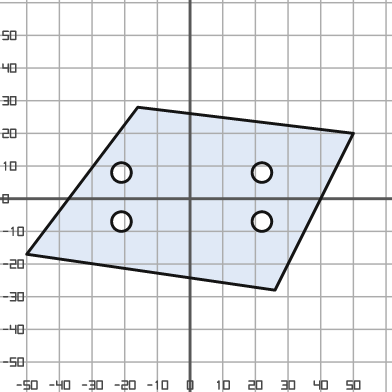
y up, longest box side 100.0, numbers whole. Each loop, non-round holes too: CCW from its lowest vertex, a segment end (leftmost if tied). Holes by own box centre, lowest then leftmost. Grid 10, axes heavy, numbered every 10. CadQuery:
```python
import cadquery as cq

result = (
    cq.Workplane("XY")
    .moveTo(26.0, -28.0)
    .lineTo(50.0, 20.0)
    .lineTo(-16.0, 28.0)
    .lineTo(-50.0, -17.0)
    .close()
    .moveTo(-21.0, -7.0)
    .circle(3.0)
    .moveTo(22.0, -7.0)
    .circle(3.0)
    .moveTo(-21.0, 8.0)
    .circle(3.0)
    .moveTo(22.0, 8.0)
    .circle(3.0)
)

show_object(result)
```